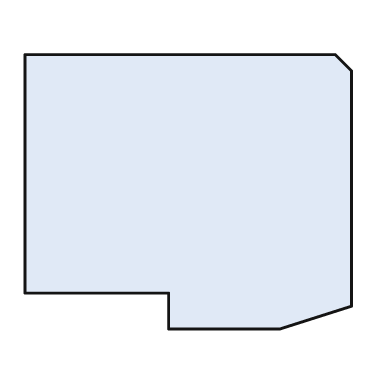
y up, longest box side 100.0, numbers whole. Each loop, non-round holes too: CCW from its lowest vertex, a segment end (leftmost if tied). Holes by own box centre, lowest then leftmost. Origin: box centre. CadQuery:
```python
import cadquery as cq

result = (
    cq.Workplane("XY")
    .moveTo(-6.0, -42.0)
    .lineTo(28.0, -42.0)
    .lineTo(50.0, -35.0)
    .lineTo(50.0, 37.0)
    .lineTo(45.0, 42.0)
    .lineTo(-50.0, 42.0)
    .lineTo(-50.0, -31.0)
    .lineTo(-6.0, -31.0)
    .close()
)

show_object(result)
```